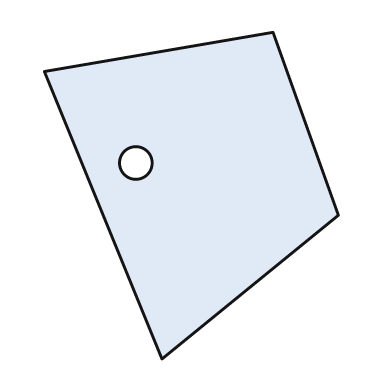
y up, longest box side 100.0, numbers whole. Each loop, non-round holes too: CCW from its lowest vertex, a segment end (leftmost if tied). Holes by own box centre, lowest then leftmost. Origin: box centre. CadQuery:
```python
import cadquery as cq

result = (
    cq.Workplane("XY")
    .moveTo(-9.0, -50.0)
    .lineTo(45.0, -6.0)
    .lineTo(25.0, 50.0)
    .lineTo(-45.0, 38.0)
    .close()
    .moveTo(-17.0, 10.0)
    .circle(5.0)
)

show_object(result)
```